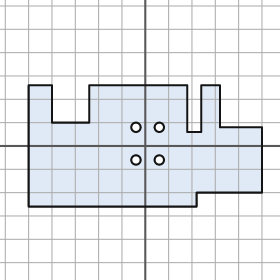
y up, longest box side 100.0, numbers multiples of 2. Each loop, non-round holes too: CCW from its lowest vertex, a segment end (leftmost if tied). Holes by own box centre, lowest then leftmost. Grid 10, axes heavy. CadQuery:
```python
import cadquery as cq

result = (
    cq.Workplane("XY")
    .moveTo(-50.0, -26.0)
    .lineTo(22.0, -26.0)
    .lineTo(22.0, -20.0)
    .lineTo(50.0, -20.0)
    .lineTo(50.0, 8.0)
    .lineTo(32.0, 8.0)
    .lineTo(32.0, 26.0)
    .lineTo(24.0, 26.0)
    .lineTo(24.0, 6.0)
    .lineTo(18.0, 6.0)
    .lineTo(18.0, 26.0)
    .lineTo(-24.0, 26.0)
    .lineTo(-24.0, 10.0)
    .lineTo(-40.0, 10.0)
    .lineTo(-40.0, 26.0)
    .lineTo(-50.0, 26.0)
    .close()
    .moveTo(-4.0, -6.0)
    .circle(2.0)
    .moveTo(6.0, -6.0)
    .circle(2.0)
    .moveTo(-4.0, 8.0)
    .circle(2.0)
    .moveTo(6.0, 8.0)
    .circle(2.0)
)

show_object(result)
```